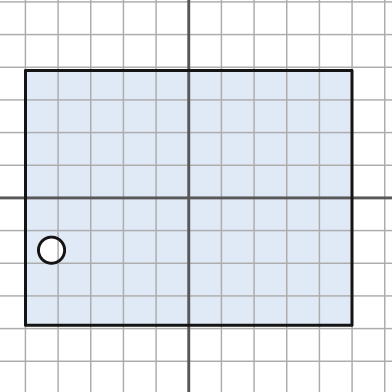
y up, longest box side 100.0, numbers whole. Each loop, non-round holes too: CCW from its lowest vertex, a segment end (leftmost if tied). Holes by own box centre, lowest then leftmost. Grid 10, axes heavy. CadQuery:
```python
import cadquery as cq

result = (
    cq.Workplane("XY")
    .moveTo(-50.0, -39.0)
    .lineTo(50.0, -39.0)
    .lineTo(50.0, 39.0)
    .lineTo(-50.0, 39.0)
    .close()
    .moveTo(-42.0, -16.0)
    .circle(4.0)
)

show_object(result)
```